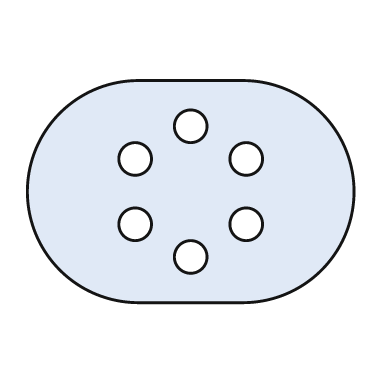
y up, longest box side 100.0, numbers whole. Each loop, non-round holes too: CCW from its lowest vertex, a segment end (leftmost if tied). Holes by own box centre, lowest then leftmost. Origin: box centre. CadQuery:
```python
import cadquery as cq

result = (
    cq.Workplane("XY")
    .moveTo(-16.0, -34.0)
    .lineTo(16.0, -34.0)
    .threePointArc((50.0, 0.0), (16.0, 34.0))
    .lineTo(-16.0, 34.0)
    .threePointArc((-50.0, 0.0), (-16.0, -34.0))
    .close()
    .moveTo(0.0, -20.0)
    .circle(5.0)
    .moveTo(-17.0, -10.0)
    .circle(5.0)
    .moveTo(17.0, -10.0)
    .circle(5.0)
    .moveTo(-17.0, 10.0)
    .circle(5.0)
    .moveTo(17.0, 10.0)
    .circle(5.0)
    .moveTo(0.0, 20.0)
    .circle(5.0)
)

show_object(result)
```